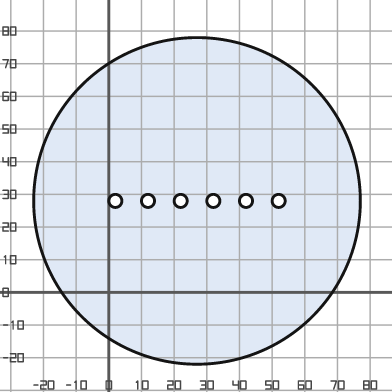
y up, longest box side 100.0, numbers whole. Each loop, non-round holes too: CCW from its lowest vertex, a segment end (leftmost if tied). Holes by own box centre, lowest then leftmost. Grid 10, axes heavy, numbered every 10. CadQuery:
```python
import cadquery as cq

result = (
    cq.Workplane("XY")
    .moveTo(27.0, 28.0)
    .circle(50.0)
    .moveTo(2.0, 28.0)
    .circle(2.0)
    .moveTo(12.0, 28.0)
    .circle(2.0)
    .moveTo(22.0, 28.0)
    .circle(2.0)
    .moveTo(32.0, 28.0)
    .circle(2.0)
    .moveTo(42.0, 28.0)
    .circle(2.0)
    .moveTo(52.0, 28.0)
    .circle(2.0)
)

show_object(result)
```